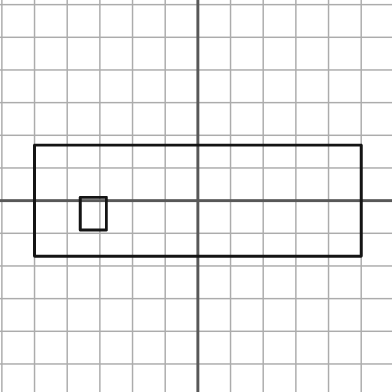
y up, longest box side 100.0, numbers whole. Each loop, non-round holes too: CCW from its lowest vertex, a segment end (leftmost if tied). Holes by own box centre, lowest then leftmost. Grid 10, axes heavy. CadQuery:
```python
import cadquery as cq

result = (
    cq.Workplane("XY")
    .moveTo(-50.0, -17.0)
    .lineTo(50.0, -17.0)
    .lineTo(50.0, 17.0)
    .lineTo(-50.0, 17.0)
    .close()
    .moveTo(-36.0, -9.0)
    .lineTo(-28.0, -9.0)
    .lineTo(-28.0, 1.0)
    .lineTo(-36.0, 1.0)
    .close()
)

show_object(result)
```